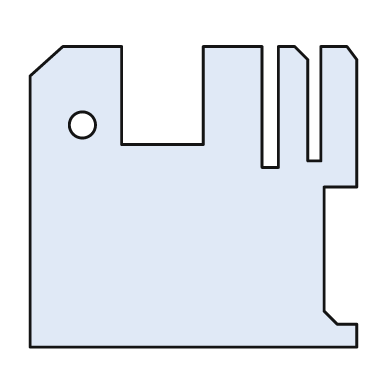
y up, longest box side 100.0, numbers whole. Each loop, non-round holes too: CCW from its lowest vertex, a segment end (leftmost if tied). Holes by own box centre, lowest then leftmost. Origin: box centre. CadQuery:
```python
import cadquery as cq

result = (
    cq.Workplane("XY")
    .moveTo(-50.0, -46.0)
    .lineTo(50.0, -46.0)
    .lineTo(50.0, -39.0)
    .lineTo(44.0, -39.0)
    .lineTo(40.0, -35.0)
    .lineTo(40.0, 3.0)
    .lineTo(50.0, 3.0)
    .lineTo(50.0, 42.0)
    .lineTo(47.0, 46.0)
    .lineTo(39.0, 46.0)
    .lineTo(39.0, 11.0)
    .lineTo(35.0, 11.0)
    .lineTo(35.0, 42.0)
    .lineTo(31.0, 46.0)
    .lineTo(26.0, 46.0)
    .lineTo(26.0, 9.0)
    .lineTo(21.0, 9.0)
    .lineTo(21.0, 46.0)
    .lineTo(3.0, 46.0)
    .lineTo(3.0, 16.0)
    .lineTo(-22.0, 16.0)
    .lineTo(-22.0, 46.0)
    .lineTo(-40.0, 46.0)
    .lineTo(-50.0, 37.0)
    .close()
    .moveTo(-34.0, 22.0)
    .circle(4.0)
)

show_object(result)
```